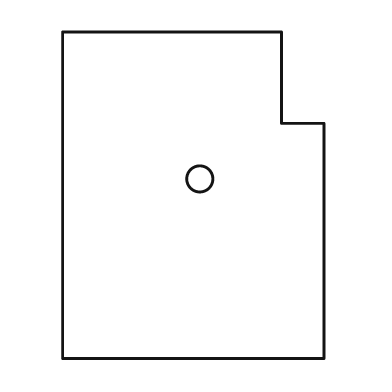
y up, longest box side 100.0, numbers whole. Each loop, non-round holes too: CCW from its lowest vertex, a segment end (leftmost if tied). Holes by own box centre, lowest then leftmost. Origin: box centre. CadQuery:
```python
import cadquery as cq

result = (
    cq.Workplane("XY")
    .moveTo(-40.0, -50.0)
    .lineTo(40.0, -50.0)
    .lineTo(40.0, 22.0)
    .lineTo(27.0, 22.0)
    .lineTo(27.0, 50.0)
    .lineTo(-40.0, 50.0)
    .close()
    .moveTo(2.0, 5.0)
    .circle(4.0)
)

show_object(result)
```